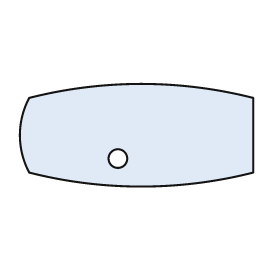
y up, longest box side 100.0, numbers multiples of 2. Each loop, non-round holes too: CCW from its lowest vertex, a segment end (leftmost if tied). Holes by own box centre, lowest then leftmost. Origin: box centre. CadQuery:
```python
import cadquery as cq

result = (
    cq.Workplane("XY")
    .moveTo(-46.0, -16.0)
    .threePointArc((2.0, -22.0), (50.0, -16.0))
    .lineTo(50.0, 16.0)
    .threePointArc((2.0, 22.0), (-46.0, 16.0))
    .threePointArc((-50.0, 0.0), (-46.0, -16.0))
    .close()
    .moveTo(-8.0, -10.0)
    .circle(4.0)
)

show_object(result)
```